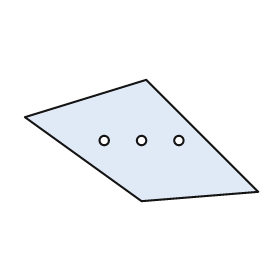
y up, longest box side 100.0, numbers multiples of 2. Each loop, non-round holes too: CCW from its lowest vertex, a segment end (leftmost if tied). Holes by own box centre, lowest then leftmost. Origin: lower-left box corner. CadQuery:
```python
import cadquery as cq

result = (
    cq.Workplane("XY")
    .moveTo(50.0, 0.0)
    .lineTo(100.0, 4.0)
    .lineTo(52.0, 52.0)
    .lineTo(0.0, 36.0)
    .close()
    .moveTo(34.0, 26.0)
    .circle(2.0)
    .moveTo(50.0, 26.0)
    .circle(2.0)
    .moveTo(66.0, 26.0)
    .circle(2.0)
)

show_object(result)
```